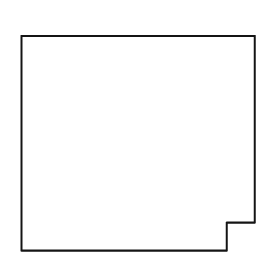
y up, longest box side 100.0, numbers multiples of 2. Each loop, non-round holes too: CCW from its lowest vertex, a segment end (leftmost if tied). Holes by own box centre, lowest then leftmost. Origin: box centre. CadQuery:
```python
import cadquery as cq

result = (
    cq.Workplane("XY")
    .moveTo(-50.0, -46.0)
    .lineTo(38.0, -46.0)
    .lineTo(38.0, -34.0)
    .lineTo(50.0, -34.0)
    .lineTo(50.0, 46.0)
    .lineTo(-50.0, 46.0)
    .close()
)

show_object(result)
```